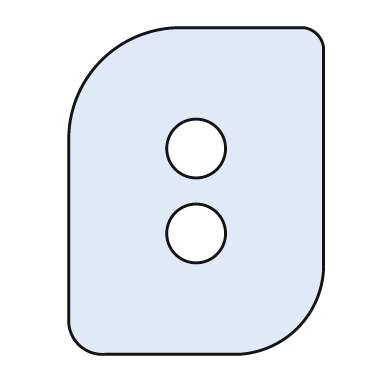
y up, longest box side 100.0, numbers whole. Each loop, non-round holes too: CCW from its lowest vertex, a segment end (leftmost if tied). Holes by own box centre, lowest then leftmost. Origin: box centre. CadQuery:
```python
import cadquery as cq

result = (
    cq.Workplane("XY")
    .moveTo(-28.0, -50.0)
    .lineTo(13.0, -50.0)
    .threePointArc((31.0, -42.0), (39.0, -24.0))
    .lineTo(39.0, 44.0)
    .threePointArc((37.0, 48.0), (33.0, 50.0))
    .lineTo(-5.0, 50.0)
    .threePointArc((-29.0, 40.0), (-39.0, 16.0))
    .lineTo(-39.0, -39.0)
    .threePointArc((-36.0, -47.0), (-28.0, -50.0))
    .close()
    .moveTo(0.0, -13.0)
    .circle(9.0)
    .moveTo(0.0, 13.0)
    .circle(9.0)
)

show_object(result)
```